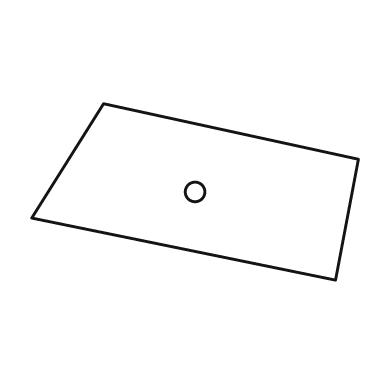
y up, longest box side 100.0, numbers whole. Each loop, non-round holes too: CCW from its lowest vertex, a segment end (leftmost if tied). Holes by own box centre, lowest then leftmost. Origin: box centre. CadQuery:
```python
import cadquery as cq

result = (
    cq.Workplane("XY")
    .moveTo(43.0, -27.0)
    .lineTo(50.0, 10.0)
    .lineTo(-28.0, 27.0)
    .lineTo(-50.0, -8.0)
    .close()
    .moveTo(0.0, 0.0)
    .circle(3.0)
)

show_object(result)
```